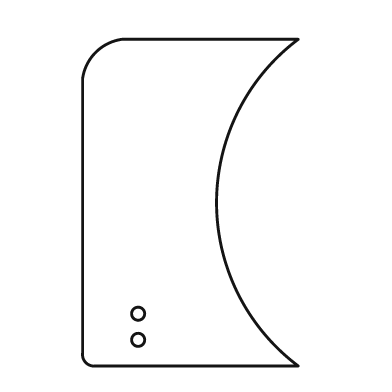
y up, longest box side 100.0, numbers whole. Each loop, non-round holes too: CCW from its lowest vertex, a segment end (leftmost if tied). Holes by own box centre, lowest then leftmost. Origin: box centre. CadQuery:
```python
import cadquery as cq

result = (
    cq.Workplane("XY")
    .moveTo(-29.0, -50.0)
    .lineTo(33.0, -50.0)
    .threePointArc((8.0, 0.0), (33.0, 50.0))
    .lineTo(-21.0, 50.0)
    .threePointArc((-29.0, 46.0), (-33.0, 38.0))
    .lineTo(-33.0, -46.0)
    .threePointArc((-32.0, -49.0), (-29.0, -50.0))
    .close()
    .moveTo(-16.0, -42.0)
    .circle(2.0)
    .moveTo(-16.0, -34.0)
    .circle(2.0)
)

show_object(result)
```